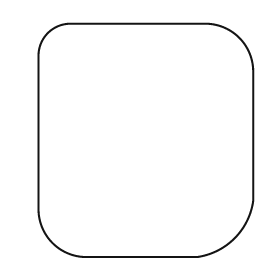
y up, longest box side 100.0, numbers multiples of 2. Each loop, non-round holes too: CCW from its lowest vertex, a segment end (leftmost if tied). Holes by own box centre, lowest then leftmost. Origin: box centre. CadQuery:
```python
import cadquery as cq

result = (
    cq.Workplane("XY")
    .moveTo(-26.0, -50.0)
    .lineTo(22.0, -50.0)
    .threePointArc((38.0, -42.0), (46.0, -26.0))
    .lineTo(46.0, 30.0)
    .threePointArc((40.0, 44.0), (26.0, 50.0))
    .lineTo(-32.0, 50.0)
    .threePointArc((-42.0, 46.0), (-46.0, 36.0))
    .lineTo(-46.0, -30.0)
    .threePointArc((-40.0, -44.0), (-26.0, -50.0))
    .close()
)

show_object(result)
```